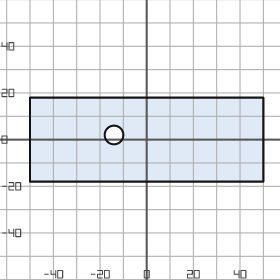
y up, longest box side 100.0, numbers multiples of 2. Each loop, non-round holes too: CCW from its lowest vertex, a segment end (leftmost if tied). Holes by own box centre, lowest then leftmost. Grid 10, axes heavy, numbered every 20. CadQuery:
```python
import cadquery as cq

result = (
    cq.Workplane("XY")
    .moveTo(-50.0, -18.0)
    .lineTo(50.0, -18.0)
    .lineTo(50.0, 18.0)
    .lineTo(-50.0, 18.0)
    .close()
    .moveTo(-14.0, 2.0)
    .circle(4.0)
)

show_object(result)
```